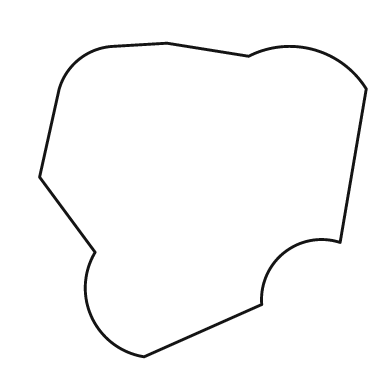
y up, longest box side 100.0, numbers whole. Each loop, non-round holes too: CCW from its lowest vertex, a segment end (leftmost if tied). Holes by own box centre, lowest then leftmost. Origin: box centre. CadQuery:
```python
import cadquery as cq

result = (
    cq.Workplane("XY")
    .moveTo(-18.0, -48.0)
    .lineTo(18.0, -32.0)
    .threePointArc((25.0, -16.0), (42.0, -13.0))
    .lineTo(50.0, 34.0)
    .threePointArc((34.0, 46.0), (14.0, 44.0))
    .lineTo(-11.0, 48.0)
    .lineTo(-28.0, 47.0)
    .threePointArc((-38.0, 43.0), (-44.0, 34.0))
    .lineTo(-50.0, 7.0)
    .lineTo(-33.0, -16.0)
    .threePointArc((-34.0, -36.0), (-18.0, -48.0))
    .close()
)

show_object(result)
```